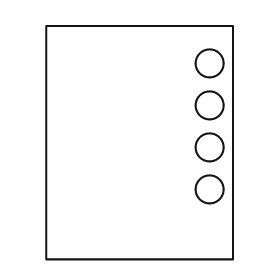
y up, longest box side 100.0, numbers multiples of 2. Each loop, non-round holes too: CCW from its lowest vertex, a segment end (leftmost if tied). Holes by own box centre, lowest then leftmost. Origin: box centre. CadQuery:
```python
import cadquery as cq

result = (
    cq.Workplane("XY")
    .moveTo(-40.0, -50.0)
    .lineTo(40.0, -50.0)
    .lineTo(40.0, 50.0)
    .lineTo(-40.0, 50.0)
    .close()
    .moveTo(30.0, -20.0)
    .circle(6.0)
    .moveTo(30.0, -2.0)
    .circle(6.0)
    .moveTo(30.0, 16.0)
    .circle(6.0)
    .moveTo(30.0, 34.0)
    .circle(6.0)
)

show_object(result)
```